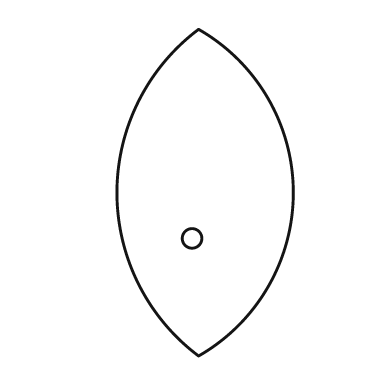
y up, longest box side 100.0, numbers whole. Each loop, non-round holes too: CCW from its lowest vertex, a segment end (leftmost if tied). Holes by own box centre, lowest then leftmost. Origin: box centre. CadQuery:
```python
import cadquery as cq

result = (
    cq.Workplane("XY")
    .moveTo(-2.0, -50.0)
    .threePointArc((27.0, 0.0), (-2.0, 50.0))
    .threePointArc((-27.0, 0.0), (-2.0, -50.0))
    .close()
    .moveTo(-4.0, -14.0)
    .circle(3.0)
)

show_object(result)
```